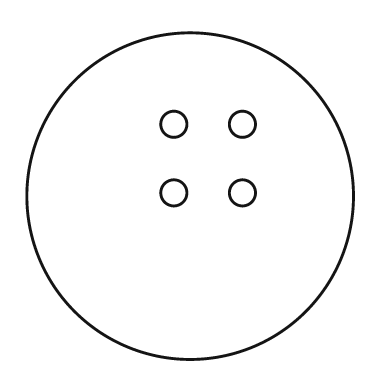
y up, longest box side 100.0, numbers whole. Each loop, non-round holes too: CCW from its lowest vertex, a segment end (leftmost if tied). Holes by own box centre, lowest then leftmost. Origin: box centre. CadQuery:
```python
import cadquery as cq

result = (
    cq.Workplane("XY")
    .moveTo(0.0, 0.0)
    .circle(50.0)
    .moveTo(-5.0, 1.0)
    .circle(4.0)
    .moveTo(16.0, 1.0)
    .circle(4.0)
    .moveTo(-5.0, 22.0)
    .circle(4.0)
    .moveTo(16.0, 22.0)
    .circle(4.0)
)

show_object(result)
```